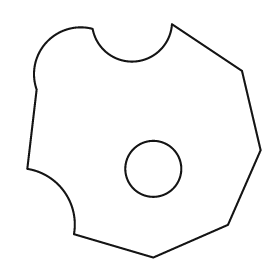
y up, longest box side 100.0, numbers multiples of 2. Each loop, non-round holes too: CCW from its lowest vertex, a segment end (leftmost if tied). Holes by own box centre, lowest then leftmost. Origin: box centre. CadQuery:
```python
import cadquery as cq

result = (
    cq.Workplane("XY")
    .moveTo(4.0, -50.0)
    .lineTo(36.0, -36.0)
    .lineTo(50.0, -4.0)
    .lineTo(42.0, 30.0)
    .lineTo(12.0, 50.0)
    .threePointArc((-4.0, 34.0), (-22.0, 48.0))
    .threePointArc((-42.0, 42.0), (-46.0, 22.0))
    .lineTo(-50.0, -12.0)
    .threePointArc((-34.0, -22.0), (-30.0, -40.0))
    .close()
    .moveTo(4.0, -12.0)
    .circle(12.0)
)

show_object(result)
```